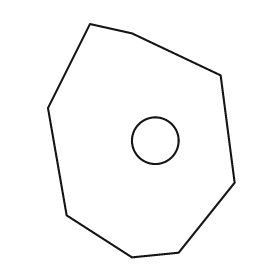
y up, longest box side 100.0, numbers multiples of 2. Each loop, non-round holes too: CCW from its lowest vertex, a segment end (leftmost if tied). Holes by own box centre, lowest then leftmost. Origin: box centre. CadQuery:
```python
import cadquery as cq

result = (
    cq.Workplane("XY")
    .moveTo(-4.0, -50.0)
    .lineTo(16.0, -48.0)
    .lineTo(40.0, -18.0)
    .lineTo(34.0, 28.0)
    .lineTo(-4.0, 46.0)
    .lineTo(-22.0, 50.0)
    .lineTo(-40.0, 14.0)
    .lineTo(-32.0, -32.0)
    .close()
    .moveTo(6.0, 0.0)
    .circle(10.0)
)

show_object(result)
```